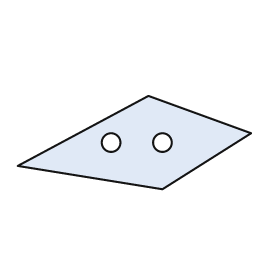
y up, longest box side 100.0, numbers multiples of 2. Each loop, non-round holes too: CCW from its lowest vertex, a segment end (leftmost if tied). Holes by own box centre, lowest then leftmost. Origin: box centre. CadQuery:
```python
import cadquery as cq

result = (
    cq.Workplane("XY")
    .moveTo(12.0, -20.0)
    .lineTo(50.0, 4.0)
    .lineTo(6.0, 20.0)
    .lineTo(-50.0, -10.0)
    .close()
    .moveTo(-10.0, 0.0)
    .circle(4.0)
    .moveTo(12.0, 0.0)
    .circle(4.0)
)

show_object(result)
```